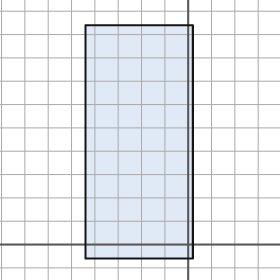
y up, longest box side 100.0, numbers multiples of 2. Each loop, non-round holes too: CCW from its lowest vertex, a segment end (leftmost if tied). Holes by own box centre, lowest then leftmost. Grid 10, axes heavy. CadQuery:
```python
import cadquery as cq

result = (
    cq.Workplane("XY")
    .moveTo(-44.0, -6.0)
    .lineTo(2.0, -6.0)
    .lineTo(2.0, 94.0)
    .lineTo(-44.0, 94.0)
    .close()
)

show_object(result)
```